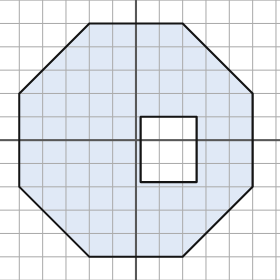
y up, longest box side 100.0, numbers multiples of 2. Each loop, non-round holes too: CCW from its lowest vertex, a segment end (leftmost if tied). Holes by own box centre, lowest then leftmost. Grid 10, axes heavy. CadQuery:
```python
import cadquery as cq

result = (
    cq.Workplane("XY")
    .moveTo(-20.0, -50.0)
    .lineTo(20.0, -50.0)
    .lineTo(50.0, -20.0)
    .lineTo(50.0, 20.0)
    .lineTo(20.0, 50.0)
    .lineTo(-20.0, 50.0)
    .lineTo(-50.0, 20.0)
    .lineTo(-50.0, -20.0)
    .close()
    .moveTo(2.0, -18.0)
    .lineTo(26.0, -18.0)
    .lineTo(26.0, 10.0)
    .lineTo(2.0, 10.0)
    .close()
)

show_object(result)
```